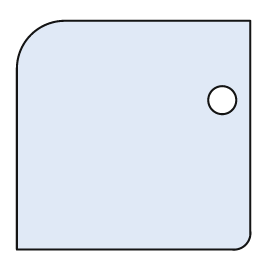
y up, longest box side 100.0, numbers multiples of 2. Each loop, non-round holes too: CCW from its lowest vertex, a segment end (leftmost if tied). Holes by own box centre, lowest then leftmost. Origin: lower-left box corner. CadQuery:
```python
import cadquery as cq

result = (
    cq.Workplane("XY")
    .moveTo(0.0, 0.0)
    .lineTo(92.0, 0.0)
    .threePointArc((98.0, 2.0), (100.0, 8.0))
    .lineTo(100.0, 98.0)
    .lineTo(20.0, 98.0)
    .threePointArc((6.0, 92.0), (0.0, 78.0))
    .close()
    .moveTo(88.0, 64.0)
    .circle(6.0)
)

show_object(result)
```